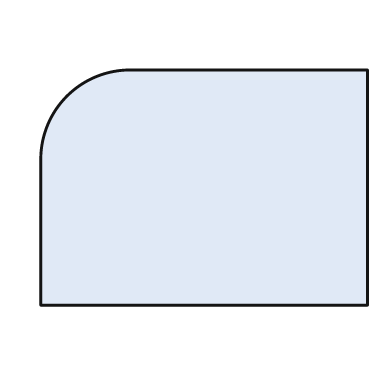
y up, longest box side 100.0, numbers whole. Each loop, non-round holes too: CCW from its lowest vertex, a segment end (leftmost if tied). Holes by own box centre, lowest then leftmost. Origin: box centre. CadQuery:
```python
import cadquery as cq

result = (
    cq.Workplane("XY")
    .moveTo(-50.0, -36.0)
    .lineTo(50.0, -36.0)
    .lineTo(50.0, 36.0)
    .lineTo(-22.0, 36.0)
    .threePointArc((-42.0, 28.0), (-50.0, 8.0))
    .close()
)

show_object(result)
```